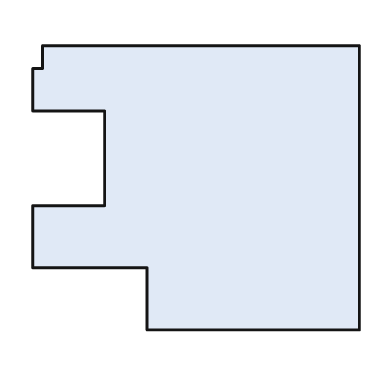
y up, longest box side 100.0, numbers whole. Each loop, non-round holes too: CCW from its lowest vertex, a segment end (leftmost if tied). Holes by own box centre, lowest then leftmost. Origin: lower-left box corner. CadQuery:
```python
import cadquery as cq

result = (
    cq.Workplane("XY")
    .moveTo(35.0, 0.0)
    .lineTo(100.0, 0.0)
    .lineTo(100.0, 87.0)
    .lineTo(3.0, 87.0)
    .lineTo(3.0, 80.0)
    .lineTo(0.0, 80.0)
    .lineTo(0.0, 67.0)
    .lineTo(22.0, 67.0)
    .lineTo(22.0, 38.0)
    .lineTo(0.0, 38.0)
    .lineTo(0.0, 19.0)
    .lineTo(35.0, 19.0)
    .close()
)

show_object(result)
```